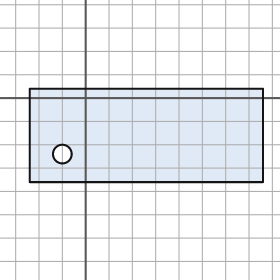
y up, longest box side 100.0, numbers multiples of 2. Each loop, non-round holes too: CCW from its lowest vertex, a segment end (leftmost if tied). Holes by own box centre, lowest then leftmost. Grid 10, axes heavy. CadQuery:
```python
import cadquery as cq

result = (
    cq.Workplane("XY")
    .moveTo(-24.0, -36.0)
    .lineTo(76.0, -36.0)
    .lineTo(76.0, 4.0)
    .lineTo(-24.0, 4.0)
    .close()
    .moveTo(-10.0, -24.0)
    .circle(4.0)
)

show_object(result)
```